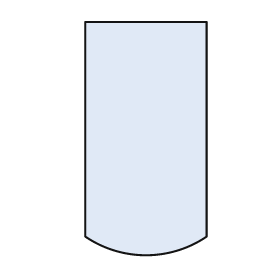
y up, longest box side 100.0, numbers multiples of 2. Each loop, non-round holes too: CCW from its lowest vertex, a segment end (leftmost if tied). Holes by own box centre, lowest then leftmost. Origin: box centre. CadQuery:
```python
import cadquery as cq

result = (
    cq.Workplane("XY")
    .moveTo(-26.0, -42.0)
    .threePointArc((0.0, -50.0), (26.0, -42.0))
    .lineTo(26.0, 50.0)
    .lineTo(-26.0, 50.0)
    .close()
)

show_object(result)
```